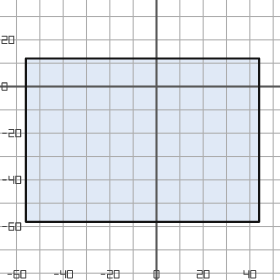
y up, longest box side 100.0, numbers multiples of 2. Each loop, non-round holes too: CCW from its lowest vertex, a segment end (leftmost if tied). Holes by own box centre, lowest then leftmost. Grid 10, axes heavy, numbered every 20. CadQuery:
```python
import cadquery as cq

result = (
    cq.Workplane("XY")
    .moveTo(-56.0, -58.0)
    .lineTo(44.0, -58.0)
    .lineTo(44.0, 12.0)
    .lineTo(-56.0, 12.0)
    .close()
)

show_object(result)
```